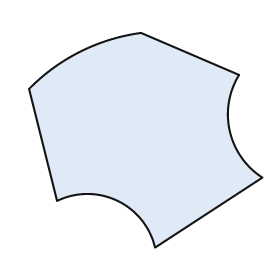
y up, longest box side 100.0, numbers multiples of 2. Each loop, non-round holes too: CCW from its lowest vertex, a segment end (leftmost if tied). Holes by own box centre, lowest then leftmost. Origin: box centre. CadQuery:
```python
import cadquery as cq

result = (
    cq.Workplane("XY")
    .moveTo(4.0, -46.0)
    .lineTo(50.0, -16.0)
    .threePointArc((36.0, 4.0), (40.0, 28.0))
    .lineTo(-2.0, 46.0)
    .threePointArc((-28.0, 38.0), (-50.0, 22.0))
    .lineTo(-38.0, -26.0)
    .threePointArc((-12.0, -26.0), (4.0, -46.0))
    .close()
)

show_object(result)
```